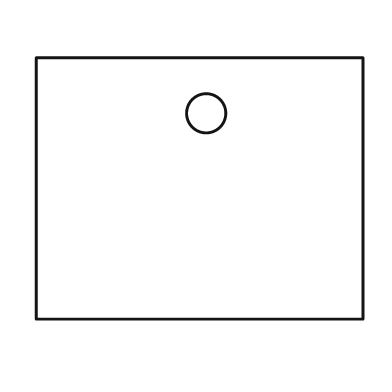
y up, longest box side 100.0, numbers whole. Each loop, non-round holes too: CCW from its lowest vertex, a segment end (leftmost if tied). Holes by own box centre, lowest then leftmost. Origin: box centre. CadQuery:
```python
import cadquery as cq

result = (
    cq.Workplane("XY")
    .moveTo(-50.0, -40.0)
    .lineTo(50.0, -40.0)
    .lineTo(50.0, 40.0)
    .lineTo(-50.0, 40.0)
    .close()
    .moveTo(2.0, 23.0)
    .circle(6.0)
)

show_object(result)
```